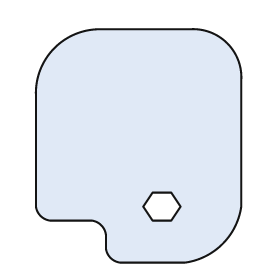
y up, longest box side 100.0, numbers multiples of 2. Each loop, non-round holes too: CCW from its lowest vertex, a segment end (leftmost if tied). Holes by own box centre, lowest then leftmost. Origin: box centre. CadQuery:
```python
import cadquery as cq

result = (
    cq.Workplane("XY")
    .moveTo(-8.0, -50.0)
    .lineTo(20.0, -50.0)
    .threePointArc((36.0, -42.0), (44.0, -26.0))
    .lineTo(44.0, 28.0)
    .threePointArc((38.0, 44.0), (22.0, 50.0))
    .lineTo(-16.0, 50.0)
    .threePointArc((-36.0, 42.0), (-44.0, 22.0))
    .lineTo(-44.0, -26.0)
    .threePointArc((-42.0, -30.0), (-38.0, -32.0))
    .lineTo(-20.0, -32.0)
    .threePointArc((-16.0, -34.0), (-14.0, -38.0))
    .lineTo(-14.0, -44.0)
    .threePointArc((-12.0, -48.0), (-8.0, -50.0))
    .close()
    .moveTo(6.0, -32.0)
    .lineTo(14.0, -32.0)
    .lineTo(18.0, -26.0)
    .lineTo(14.0, -20.0)
    .lineTo(6.0, -20.0)
    .lineTo(2.0, -26.0)
    .close()
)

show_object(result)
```